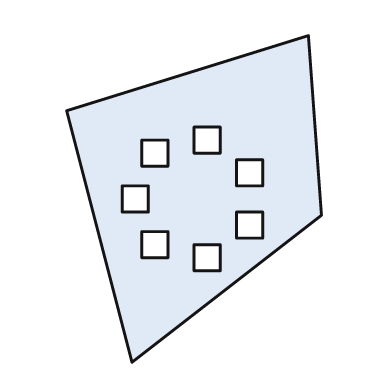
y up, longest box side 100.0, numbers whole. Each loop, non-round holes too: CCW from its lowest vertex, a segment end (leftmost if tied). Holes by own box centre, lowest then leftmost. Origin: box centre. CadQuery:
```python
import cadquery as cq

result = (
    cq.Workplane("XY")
    .moveTo(-19.0, -50.0)
    .lineTo(39.0, -5.0)
    .lineTo(35.0, 50.0)
    .lineTo(-39.0, 27.0)
    .close()
    .moveTo(0.0, -22.0)
    .lineTo(8.0, -22.0)
    .lineTo(8.0, -14.0)
    .lineTo(0.0, -14.0)
    .close()
    .moveTo(-16.0, -18.0)
    .lineTo(-8.0, -18.0)
    .lineTo(-8.0, -10.0)
    .lineTo(-16.0, -10.0)
    .close()
    .moveTo(13.0, -12.0)
    .lineTo(21.0, -12.0)
    .lineTo(21.0, -4.0)
    .lineTo(13.0, -4.0)
    .close()
    .moveTo(-22.0, -4.0)
    .lineTo(-14.0, -4.0)
    .lineTo(-14.0, 4.0)
    .lineTo(-22.0, 4.0)
    .close()
    .moveTo(13.0, 4.0)
    .lineTo(21.0, 4.0)
    .lineTo(21.0, 12.0)
    .lineTo(13.0, 12.0)
    .close()
    .moveTo(-16.0, 10.0)
    .lineTo(-8.0, 10.0)
    .lineTo(-8.0, 18.0)
    .lineTo(-16.0, 18.0)
    .close()
    .moveTo(0.0, 14.0)
    .lineTo(8.0, 14.0)
    .lineTo(8.0, 22.0)
    .lineTo(0.0, 22.0)
    .close()
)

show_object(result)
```